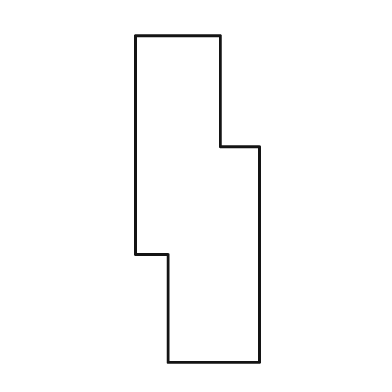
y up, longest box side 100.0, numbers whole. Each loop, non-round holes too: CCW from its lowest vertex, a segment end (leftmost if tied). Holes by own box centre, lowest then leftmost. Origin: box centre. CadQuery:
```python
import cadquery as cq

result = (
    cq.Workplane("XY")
    .moveTo(-9.0, -50.0)
    .lineTo(19.0, -50.0)
    .lineTo(19.0, 16.0)
    .lineTo(7.0, 16.0)
    .lineTo(7.0, 50.0)
    .lineTo(-19.0, 50.0)
    .lineTo(-19.0, -17.0)
    .lineTo(-9.0, -17.0)
    .close()
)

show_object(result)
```